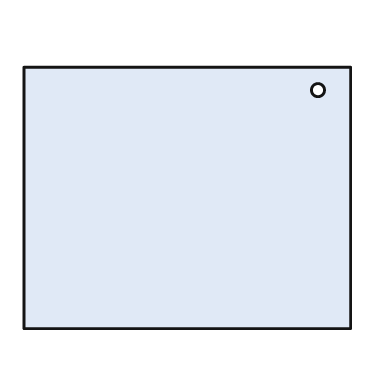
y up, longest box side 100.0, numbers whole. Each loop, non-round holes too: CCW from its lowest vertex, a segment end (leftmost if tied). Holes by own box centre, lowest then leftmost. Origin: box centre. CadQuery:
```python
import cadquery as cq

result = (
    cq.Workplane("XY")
    .moveTo(-50.0, -40.0)
    .lineTo(50.0, -40.0)
    .lineTo(50.0, 40.0)
    .lineTo(-50.0, 40.0)
    .close()
    .moveTo(40.0, 33.0)
    .circle(2.0)
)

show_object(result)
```